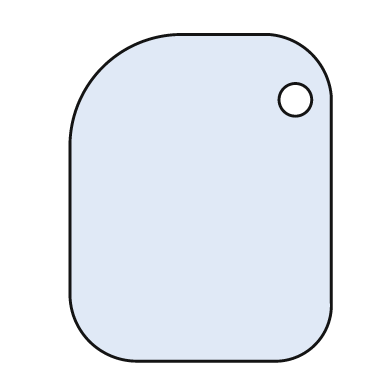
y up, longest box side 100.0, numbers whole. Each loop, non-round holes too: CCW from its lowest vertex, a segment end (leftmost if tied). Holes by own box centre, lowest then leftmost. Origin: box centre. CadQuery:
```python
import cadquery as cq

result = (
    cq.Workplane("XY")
    .moveTo(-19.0, -50.0)
    .lineTo(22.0, -50.0)
    .threePointArc((35.0, -45.0), (40.0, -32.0))
    .lineTo(40.0, 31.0)
    .threePointArc((34.0, 44.0), (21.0, 50.0))
    .lineTo(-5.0, 50.0)
    .threePointArc((-30.0, 40.0), (-40.0, 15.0))
    .lineTo(-40.0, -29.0)
    .threePointArc((-34.0, -44.0), (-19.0, -50.0))
    .close()
    .moveTo(29.0, 30.0)
    .circle(5.0)
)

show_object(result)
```